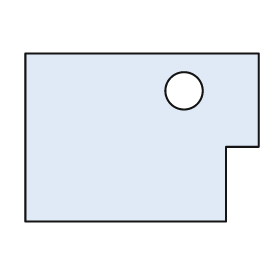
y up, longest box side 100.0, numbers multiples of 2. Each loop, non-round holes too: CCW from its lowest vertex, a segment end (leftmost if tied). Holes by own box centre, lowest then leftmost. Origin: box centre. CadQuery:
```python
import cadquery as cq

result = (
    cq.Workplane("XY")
    .moveTo(-50.0, -36.0)
    .lineTo(36.0, -36.0)
    .lineTo(36.0, -4.0)
    .lineTo(50.0, -4.0)
    .lineTo(50.0, 36.0)
    .lineTo(-50.0, 36.0)
    .close()
    .moveTo(18.0, 20.0)
    .circle(8.0)
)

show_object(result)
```